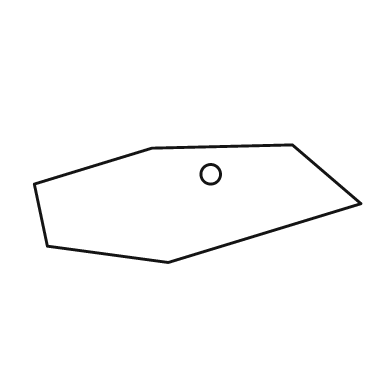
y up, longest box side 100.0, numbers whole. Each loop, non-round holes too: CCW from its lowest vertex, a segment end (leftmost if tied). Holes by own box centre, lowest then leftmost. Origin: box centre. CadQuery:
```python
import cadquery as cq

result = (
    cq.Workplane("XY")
    .moveTo(-9.0, -18.0)
    .lineTo(50.0, 0.0)
    .lineTo(29.0, 18.0)
    .lineTo(-14.0, 17.0)
    .lineTo(-50.0, 6.0)
    .lineTo(-46.0, -13.0)
    .close()
    .moveTo(4.0, 9.0)
    .circle(3.0)
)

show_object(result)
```